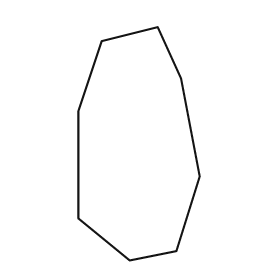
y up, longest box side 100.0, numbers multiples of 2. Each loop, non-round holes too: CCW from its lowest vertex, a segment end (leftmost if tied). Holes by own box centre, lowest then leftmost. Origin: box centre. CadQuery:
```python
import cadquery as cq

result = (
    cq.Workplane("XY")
    .moveTo(-4.0, -50.0)
    .lineTo(16.0, -46.0)
    .lineTo(26.0, -14.0)
    .lineTo(18.0, 28.0)
    .lineTo(8.0, 50.0)
    .lineTo(-16.0, 44.0)
    .lineTo(-26.0, 14.0)
    .lineTo(-26.0, -32.0)
    .close()
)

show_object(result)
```